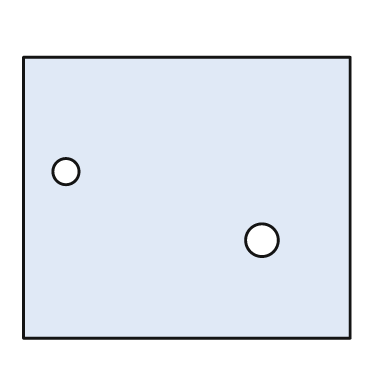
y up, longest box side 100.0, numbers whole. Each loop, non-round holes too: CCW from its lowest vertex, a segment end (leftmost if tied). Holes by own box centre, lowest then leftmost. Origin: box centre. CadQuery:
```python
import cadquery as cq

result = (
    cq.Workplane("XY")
    .moveTo(-50.0, -43.0)
    .lineTo(50.0, -43.0)
    .lineTo(50.0, 43.0)
    .lineTo(-50.0, 43.0)
    .close()
    .moveTo(23.0, -13.0)
    .circle(5.0)
    .moveTo(-37.0, 8.0)
    .circle(4.0)
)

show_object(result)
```